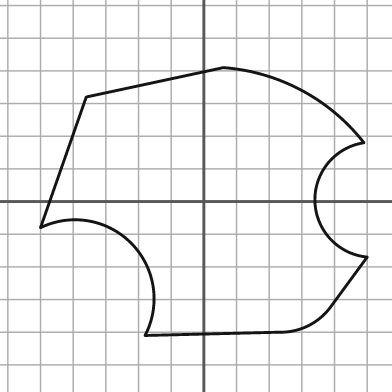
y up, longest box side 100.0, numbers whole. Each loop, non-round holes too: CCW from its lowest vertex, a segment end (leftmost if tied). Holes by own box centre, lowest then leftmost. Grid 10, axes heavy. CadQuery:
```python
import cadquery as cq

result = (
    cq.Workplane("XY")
    .moveTo(-18.0, -41.0)
    .lineTo(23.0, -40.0)
    .threePointArc((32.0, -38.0), (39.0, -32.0))
    .lineTo(50.0, -17.0)
    .threePointArc((34.0, 0.0), (49.0, 18.0))
    .threePointArc((30.0, 34.0), (6.0, 41.0))
    .lineTo(-36.0, 32.0)
    .lineTo(-50.0, -8.0)
    .threePointArc((-22.0, -13.0), (-18.0, -41.0))
    .close()
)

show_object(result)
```